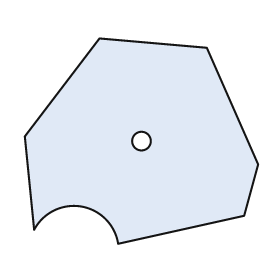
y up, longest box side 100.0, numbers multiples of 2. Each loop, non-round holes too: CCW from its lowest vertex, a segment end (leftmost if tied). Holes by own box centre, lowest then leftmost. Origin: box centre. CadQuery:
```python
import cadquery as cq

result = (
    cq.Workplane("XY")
    .moveTo(-10.0, -44.0)
    .lineTo(44.0, -32.0)
    .lineTo(50.0, -10.0)
    .lineTo(28.0, 40.0)
    .lineTo(-18.0, 44.0)
    .lineTo(-50.0, 2.0)
    .lineTo(-46.0, -38.0)
    .threePointArc((-26.0, -28.0), (-10.0, -44.0))
    .close()
    .moveTo(0.0, 0.0)
    .circle(4.0)
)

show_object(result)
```